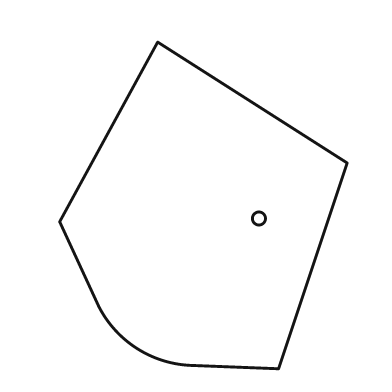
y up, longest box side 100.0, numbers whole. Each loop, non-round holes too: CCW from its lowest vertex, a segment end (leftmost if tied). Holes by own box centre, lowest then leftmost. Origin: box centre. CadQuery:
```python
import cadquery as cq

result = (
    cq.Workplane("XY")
    .moveTo(23.0, -50.0)
    .lineTo(44.0, 13.0)
    .lineTo(-14.0, 50.0)
    .lineTo(-44.0, -5.0)
    .lineTo(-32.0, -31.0)
    .threePointArc((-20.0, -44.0), (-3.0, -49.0))
    .close()
    .moveTo(17.0, -4.0)
    .circle(2.0)
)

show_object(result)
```